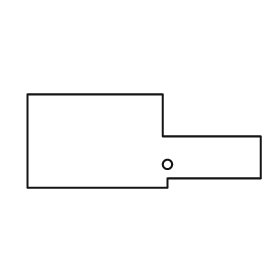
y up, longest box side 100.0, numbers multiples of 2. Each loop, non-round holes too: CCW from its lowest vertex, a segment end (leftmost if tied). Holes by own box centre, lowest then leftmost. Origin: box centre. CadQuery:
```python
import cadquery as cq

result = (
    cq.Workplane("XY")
    .moveTo(-50.0, -20.0)
    .lineTo(10.0, -20.0)
    .lineTo(10.0, -16.0)
    .lineTo(50.0, -16.0)
    .lineTo(50.0, 2.0)
    .lineTo(8.0, 2.0)
    .lineTo(8.0, 20.0)
    .lineTo(-50.0, 20.0)
    .close()
    .moveTo(10.0, -10.0)
    .circle(2.0)
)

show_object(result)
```